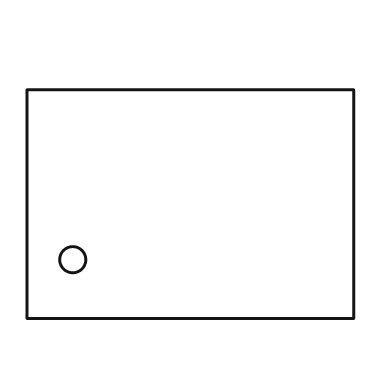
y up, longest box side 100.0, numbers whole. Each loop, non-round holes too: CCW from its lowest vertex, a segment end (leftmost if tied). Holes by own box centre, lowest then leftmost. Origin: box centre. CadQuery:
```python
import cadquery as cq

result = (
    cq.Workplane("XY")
    .moveTo(-50.0, -35.0)
    .lineTo(50.0, -35.0)
    .lineTo(50.0, 35.0)
    .lineTo(-50.0, 35.0)
    .close()
    .moveTo(-36.0, -17.0)
    .circle(4.0)
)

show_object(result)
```